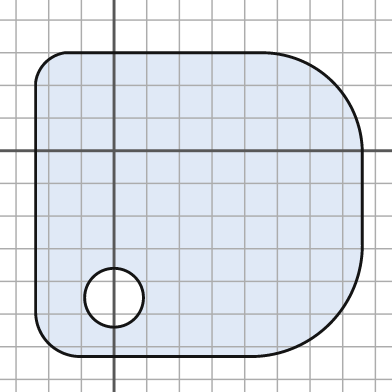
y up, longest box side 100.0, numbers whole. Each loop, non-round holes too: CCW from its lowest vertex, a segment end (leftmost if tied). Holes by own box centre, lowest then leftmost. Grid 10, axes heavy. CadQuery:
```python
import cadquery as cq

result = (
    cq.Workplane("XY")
    .moveTo(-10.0, -63.0)
    .lineTo(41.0, -63.0)
    .threePointArc((66.0, -53.0), (76.0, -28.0))
    .lineTo(76.0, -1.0)
    .threePointArc((67.0, 21.0), (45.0, 30.0))
    .lineTo(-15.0, 30.0)
    .threePointArc((-21.0, 27.0), (-24.0, 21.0))
    .lineTo(-24.0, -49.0)
    .threePointArc((-20.0, -59.0), (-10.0, -63.0))
    .close()
    .moveTo(0.0, -45.0)
    .circle(9.0)
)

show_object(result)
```